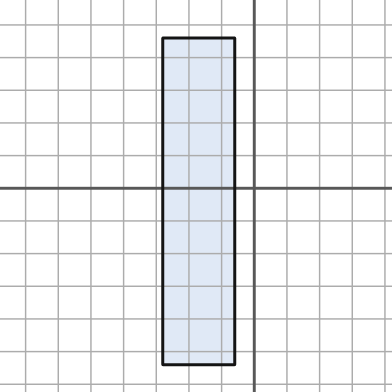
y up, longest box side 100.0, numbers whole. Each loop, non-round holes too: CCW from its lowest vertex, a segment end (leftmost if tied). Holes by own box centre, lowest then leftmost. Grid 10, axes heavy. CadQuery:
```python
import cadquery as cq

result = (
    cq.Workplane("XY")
    .moveTo(-28.0, -54.0)
    .lineTo(-6.0, -54.0)
    .lineTo(-6.0, 46.0)
    .lineTo(-28.0, 46.0)
    .close()
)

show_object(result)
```